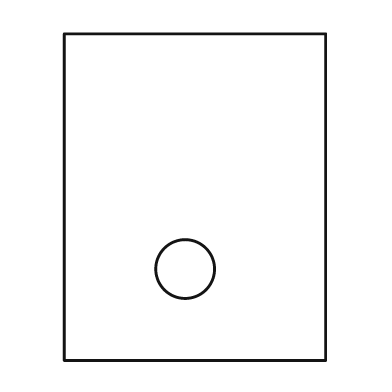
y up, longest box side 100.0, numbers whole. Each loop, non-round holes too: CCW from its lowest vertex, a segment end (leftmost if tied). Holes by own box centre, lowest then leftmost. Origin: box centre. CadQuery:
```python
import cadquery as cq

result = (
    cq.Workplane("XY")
    .moveTo(-40.0, -50.0)
    .lineTo(40.0, -50.0)
    .lineTo(40.0, 50.0)
    .lineTo(-40.0, 50.0)
    .close()
    .moveTo(-3.0, -22.0)
    .circle(9.0)
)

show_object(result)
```